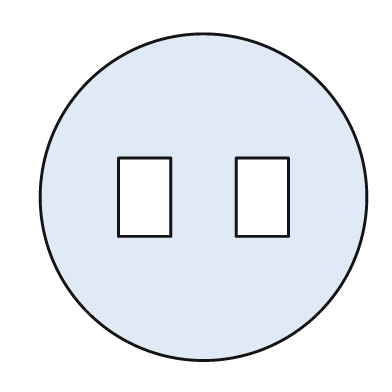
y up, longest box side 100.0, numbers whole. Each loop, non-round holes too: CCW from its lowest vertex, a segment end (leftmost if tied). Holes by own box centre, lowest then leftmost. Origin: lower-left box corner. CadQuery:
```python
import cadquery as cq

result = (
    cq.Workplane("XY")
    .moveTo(50.0, 50.0)
    .circle(50.0)
    .moveTo(24.0, 38.0)
    .lineTo(40.0, 38.0)
    .lineTo(40.0, 62.0)
    .lineTo(24.0, 62.0)
    .close()
    .moveTo(60.0, 38.0)
    .lineTo(76.0, 38.0)
    .lineTo(76.0, 62.0)
    .lineTo(60.0, 62.0)
    .close()
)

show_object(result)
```